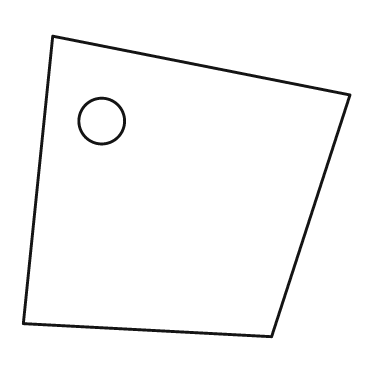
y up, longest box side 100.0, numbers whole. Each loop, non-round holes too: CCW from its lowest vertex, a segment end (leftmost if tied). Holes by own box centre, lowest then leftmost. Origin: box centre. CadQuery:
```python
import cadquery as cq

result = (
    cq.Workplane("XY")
    .moveTo(26.0, -46.0)
    .lineTo(50.0, 28.0)
    .lineTo(-41.0, 46.0)
    .lineTo(-50.0, -42.0)
    .close()
    .moveTo(-26.0, 20.0)
    .circle(7.0)
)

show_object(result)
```